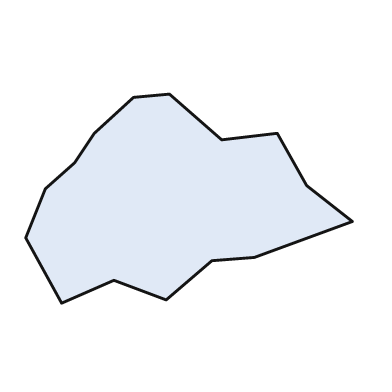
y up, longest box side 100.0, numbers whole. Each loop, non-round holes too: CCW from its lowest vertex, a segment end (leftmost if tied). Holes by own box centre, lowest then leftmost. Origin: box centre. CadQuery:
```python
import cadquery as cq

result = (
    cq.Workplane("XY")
    .moveTo(-39.0, -32.0)
    .lineTo(-23.0, -25.0)
    .lineTo(-7.0, -31.0)
    .lineTo(7.0, -19.0)
    .lineTo(20.0, -18.0)
    .lineTo(50.0, -7.0)
    .lineTo(36.0, 4.0)
    .lineTo(27.0, 20.0)
    .lineTo(10.0, 18.0)
    .lineTo(-6.0, 32.0)
    .lineTo(-17.0, 31.0)
    .lineTo(-29.0, 20.0)
    .lineTo(-35.0, 11.0)
    .lineTo(-44.0, 3.0)
    .lineTo(-50.0, -12.0)
    .close()
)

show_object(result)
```